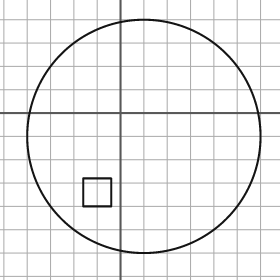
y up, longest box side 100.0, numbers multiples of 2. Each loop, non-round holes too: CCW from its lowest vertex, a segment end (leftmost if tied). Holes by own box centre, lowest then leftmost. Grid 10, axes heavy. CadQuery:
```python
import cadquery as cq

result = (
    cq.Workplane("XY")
    .moveTo(10.0, -10.0)
    .circle(50.0)
    .moveTo(-16.0, -40.0)
    .lineTo(-4.0, -40.0)
    .lineTo(-4.0, -28.0)
    .lineTo(-16.0, -28.0)
    .close()
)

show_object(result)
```